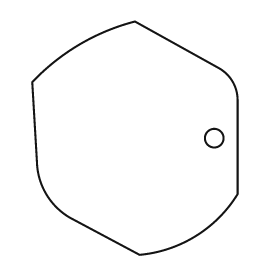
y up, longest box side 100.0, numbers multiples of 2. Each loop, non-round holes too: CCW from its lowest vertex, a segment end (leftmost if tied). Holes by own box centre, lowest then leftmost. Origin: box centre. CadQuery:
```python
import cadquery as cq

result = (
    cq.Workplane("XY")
    .moveTo(2.0, -50.0)
    .threePointArc((26.0, -42.0), (44.0, -24.0))
    .lineTo(44.0, 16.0)
    .threePointArc((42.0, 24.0), (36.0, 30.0))
    .lineTo(0.0, 50.0)
    .threePointArc((-24.0, 40.0), (-44.0, 24.0))
    .lineTo(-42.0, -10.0)
    .threePointArc((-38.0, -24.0), (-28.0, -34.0))
    .close()
    .moveTo(34.0, 0.0)
    .circle(4.0)
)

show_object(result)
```